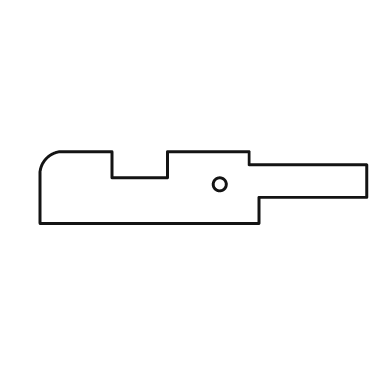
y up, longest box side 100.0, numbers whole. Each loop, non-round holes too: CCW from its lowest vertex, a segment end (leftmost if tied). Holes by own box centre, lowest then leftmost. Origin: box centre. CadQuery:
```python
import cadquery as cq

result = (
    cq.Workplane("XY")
    .moveTo(-50.0, -11.0)
    .lineTo(17.0, -11.0)
    .lineTo(17.0, -3.0)
    .lineTo(50.0, -3.0)
    .lineTo(50.0, 7.0)
    .lineTo(14.0, 7.0)
    .lineTo(14.0, 11.0)
    .lineTo(-11.0, 11.0)
    .lineTo(-11.0, 3.0)
    .lineTo(-28.0, 3.0)
    .lineTo(-28.0, 11.0)
    .lineTo(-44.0, 11.0)
    .threePointArc((-48.0, 9.0), (-50.0, 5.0))
    .close()
    .moveTo(5.0, 1.0)
    .circle(2.0)
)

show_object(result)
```